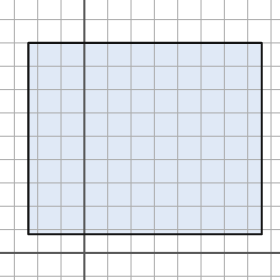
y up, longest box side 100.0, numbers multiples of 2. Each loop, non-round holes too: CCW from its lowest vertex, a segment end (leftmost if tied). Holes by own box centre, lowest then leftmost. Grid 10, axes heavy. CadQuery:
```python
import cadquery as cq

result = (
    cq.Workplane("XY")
    .moveTo(-24.0, 8.0)
    .lineTo(76.0, 8.0)
    .lineTo(76.0, 90.0)
    .lineTo(-24.0, 90.0)
    .close()
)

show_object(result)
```